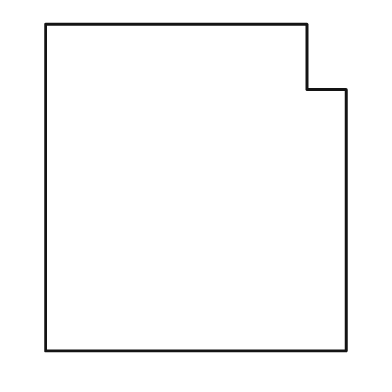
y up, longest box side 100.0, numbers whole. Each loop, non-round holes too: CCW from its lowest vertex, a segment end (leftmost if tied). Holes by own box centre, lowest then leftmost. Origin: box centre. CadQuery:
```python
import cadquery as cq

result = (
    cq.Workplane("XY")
    .moveTo(-46.0, -50.0)
    .lineTo(46.0, -50.0)
    .lineTo(46.0, 30.0)
    .lineTo(34.0, 30.0)
    .lineTo(34.0, 50.0)
    .lineTo(-46.0, 50.0)
    .close()
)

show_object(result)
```